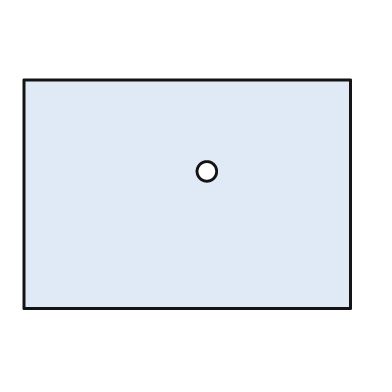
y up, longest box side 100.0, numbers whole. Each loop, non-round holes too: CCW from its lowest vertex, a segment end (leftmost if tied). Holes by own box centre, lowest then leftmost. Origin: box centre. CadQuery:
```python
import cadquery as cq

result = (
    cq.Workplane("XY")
    .moveTo(-50.0, -35.0)
    .lineTo(50.0, -35.0)
    .lineTo(50.0, 35.0)
    .lineTo(-50.0, 35.0)
    .close()
    .moveTo(6.0, 7.0)
    .circle(3.0)
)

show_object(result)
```